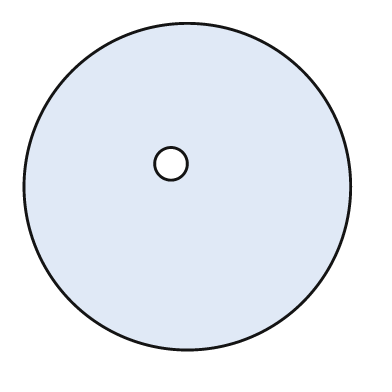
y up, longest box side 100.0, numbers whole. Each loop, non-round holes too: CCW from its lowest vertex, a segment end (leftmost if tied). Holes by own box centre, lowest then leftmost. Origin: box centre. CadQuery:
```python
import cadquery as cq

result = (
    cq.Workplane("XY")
    .moveTo(0.0, 0.0)
    .circle(50.0)
    .moveTo(-5.0, 7.0)
    .circle(5.0)
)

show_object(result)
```